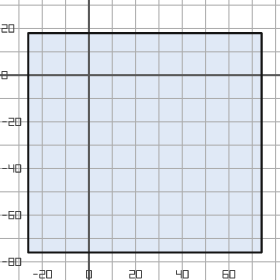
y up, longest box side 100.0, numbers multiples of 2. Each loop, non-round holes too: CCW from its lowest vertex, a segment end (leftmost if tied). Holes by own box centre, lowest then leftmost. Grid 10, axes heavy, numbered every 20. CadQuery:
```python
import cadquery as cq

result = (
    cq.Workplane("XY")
    .moveTo(-26.0, -76.0)
    .lineTo(74.0, -76.0)
    .lineTo(74.0, 18.0)
    .lineTo(-26.0, 18.0)
    .close()
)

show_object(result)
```